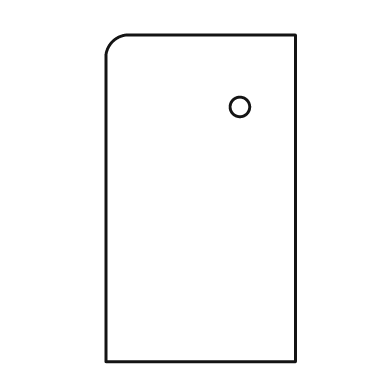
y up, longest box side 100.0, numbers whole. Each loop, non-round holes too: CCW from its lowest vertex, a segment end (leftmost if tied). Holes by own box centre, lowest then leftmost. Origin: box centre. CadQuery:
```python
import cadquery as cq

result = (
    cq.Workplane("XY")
    .moveTo(-29.0, -50.0)
    .lineTo(29.0, -50.0)
    .lineTo(29.0, 50.0)
    .lineTo(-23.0, 50.0)
    .threePointArc((-27.0, 48.0), (-29.0, 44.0))
    .close()
    .moveTo(12.0, 28.0)
    .circle(3.0)
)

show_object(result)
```